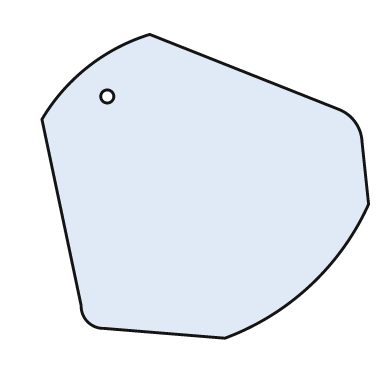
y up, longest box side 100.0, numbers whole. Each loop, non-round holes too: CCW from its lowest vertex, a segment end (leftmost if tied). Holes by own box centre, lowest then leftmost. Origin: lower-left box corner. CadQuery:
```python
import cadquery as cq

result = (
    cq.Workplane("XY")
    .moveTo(56.0, 0.0)
    .threePointArc((82.0, 16.0), (100.0, 41.0))
    .lineTo(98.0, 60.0)
    .threePointArc((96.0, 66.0), (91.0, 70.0))
    .lineTo(33.0, 93.0)
    .threePointArc((14.0, 83.0), (0.0, 67.0))
    .lineTo(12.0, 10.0)
    .threePointArc((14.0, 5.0), (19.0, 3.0))
    .close()
    .moveTo(20.0, 74.0)
    .circle(2.0)
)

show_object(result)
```